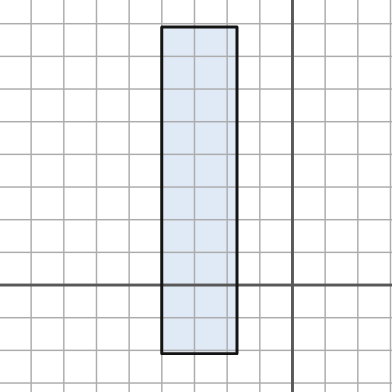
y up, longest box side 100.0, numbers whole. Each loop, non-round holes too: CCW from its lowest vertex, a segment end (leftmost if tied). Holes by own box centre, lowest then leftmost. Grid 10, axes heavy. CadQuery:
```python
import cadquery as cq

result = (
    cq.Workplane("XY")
    .moveTo(-40.0, -21.0)
    .lineTo(-17.0, -21.0)
    .lineTo(-17.0, 79.0)
    .lineTo(-40.0, 79.0)
    .close()
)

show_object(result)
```